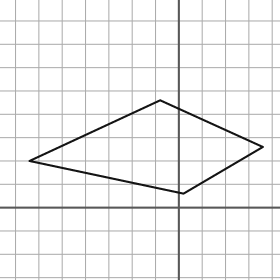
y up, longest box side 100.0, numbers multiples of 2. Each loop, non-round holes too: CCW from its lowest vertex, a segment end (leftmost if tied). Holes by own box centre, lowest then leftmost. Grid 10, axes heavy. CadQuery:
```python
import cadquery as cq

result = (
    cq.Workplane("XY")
    .moveTo(2.0, 6.0)
    .lineTo(36.0, 26.0)
    .lineTo(-8.0, 46.0)
    .lineTo(-64.0, 20.0)
    .close()
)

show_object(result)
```